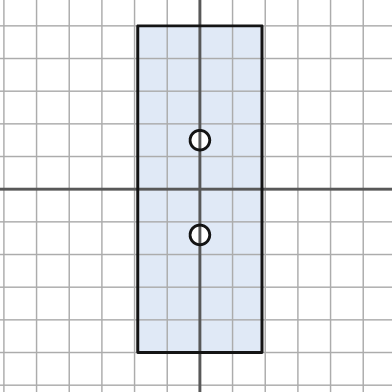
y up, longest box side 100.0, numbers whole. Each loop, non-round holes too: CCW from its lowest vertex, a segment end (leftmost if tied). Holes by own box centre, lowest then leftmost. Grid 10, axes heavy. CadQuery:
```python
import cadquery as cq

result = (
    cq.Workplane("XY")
    .moveTo(-19.0, -50.0)
    .lineTo(19.0, -50.0)
    .lineTo(19.0, 50.0)
    .lineTo(-19.0, 50.0)
    .close()
    .moveTo(0.0, -14.0)
    .circle(3.0)
    .moveTo(0.0, 15.0)
    .circle(3.0)
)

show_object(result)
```